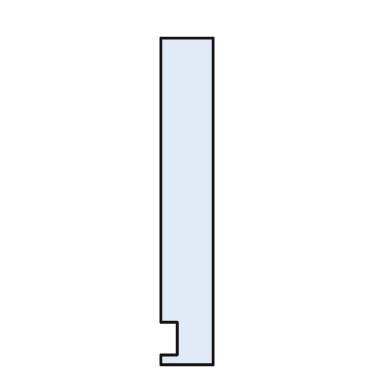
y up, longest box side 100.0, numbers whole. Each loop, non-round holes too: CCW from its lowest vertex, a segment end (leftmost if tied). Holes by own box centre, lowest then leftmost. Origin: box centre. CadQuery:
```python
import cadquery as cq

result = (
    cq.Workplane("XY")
    .moveTo(-8.0, -50.0)
    .lineTo(8.0, -50.0)
    .lineTo(8.0, 50.0)
    .lineTo(-8.0, 50.0)
    .lineTo(-8.0, -37.0)
    .lineTo(-3.0, -37.0)
    .lineTo(-3.0, -47.0)
    .lineTo(-8.0, -47.0)
    .close()
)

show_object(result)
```